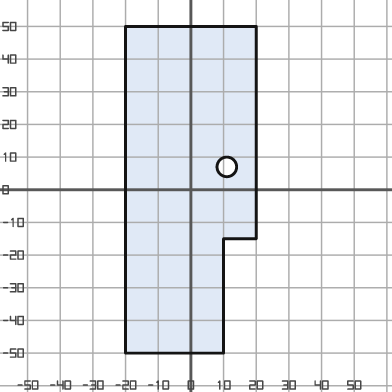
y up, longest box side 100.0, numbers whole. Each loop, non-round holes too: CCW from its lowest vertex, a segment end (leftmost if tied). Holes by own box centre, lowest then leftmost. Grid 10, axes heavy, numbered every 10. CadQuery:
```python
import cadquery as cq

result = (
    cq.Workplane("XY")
    .moveTo(-20.0, -50.0)
    .lineTo(10.0, -50.0)
    .lineTo(10.0, -15.0)
    .lineTo(20.0, -15.0)
    .lineTo(20.0, 50.0)
    .lineTo(-20.0, 50.0)
    .close()
    .moveTo(11.0, 7.0)
    .circle(3.0)
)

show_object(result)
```